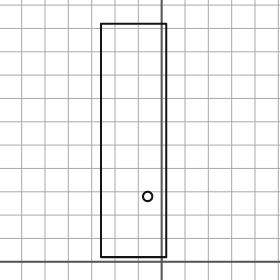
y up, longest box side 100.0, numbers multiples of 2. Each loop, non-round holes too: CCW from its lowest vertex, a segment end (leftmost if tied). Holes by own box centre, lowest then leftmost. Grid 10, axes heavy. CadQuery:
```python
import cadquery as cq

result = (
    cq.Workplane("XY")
    .moveTo(-26.0, 2.0)
    .lineTo(2.0, 2.0)
    .lineTo(2.0, 102.0)
    .lineTo(-26.0, 102.0)
    .close()
    .moveTo(-6.0, 28.0)
    .circle(2.0)
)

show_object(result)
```